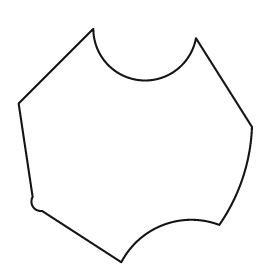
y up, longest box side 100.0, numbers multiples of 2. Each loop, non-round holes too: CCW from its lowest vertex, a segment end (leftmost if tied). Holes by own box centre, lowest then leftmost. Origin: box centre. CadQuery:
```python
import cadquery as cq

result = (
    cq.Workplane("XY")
    .moveTo(-6.0, -50.0)
    .threePointArc((12.0, -34.0), (36.0, -34.0))
    .threePointArc((46.0, -14.0), (50.0, 8.0))
    .lineTo(26.0, 46.0)
    .threePointArc((2.0, 28.0), (-18.0, 50.0))
    .lineTo(-50.0, 18.0)
    .lineTo(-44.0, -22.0)
    .threePointArc((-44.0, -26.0), (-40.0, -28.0))
    .close()
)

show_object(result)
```